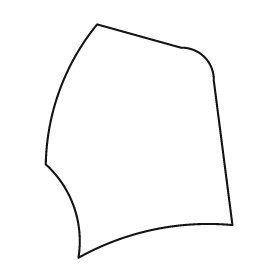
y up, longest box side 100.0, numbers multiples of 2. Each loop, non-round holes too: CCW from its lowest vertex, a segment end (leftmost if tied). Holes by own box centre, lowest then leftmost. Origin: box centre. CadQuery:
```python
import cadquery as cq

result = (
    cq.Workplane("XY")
    .moveTo(-26.0, -50.0)
    .threePointArc((6.0, -38.0), (40.0, -36.0))
    .lineTo(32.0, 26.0)
    .threePointArc((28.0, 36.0), (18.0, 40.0))
    .lineTo(-18.0, 50.0)
    .threePointArc((-34.0, 22.0), (-40.0, -10.0))
    .threePointArc((-28.0, -28.0), (-26.0, -50.0))
    .close()
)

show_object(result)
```